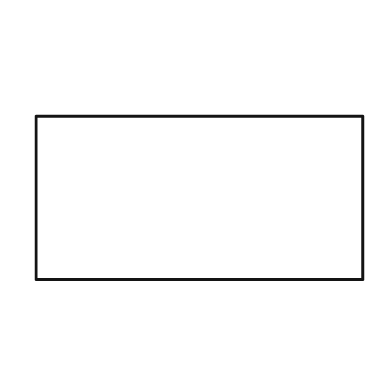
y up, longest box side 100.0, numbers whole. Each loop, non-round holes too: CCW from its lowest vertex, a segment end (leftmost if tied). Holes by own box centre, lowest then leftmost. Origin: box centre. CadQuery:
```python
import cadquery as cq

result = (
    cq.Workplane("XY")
    .moveTo(-50.0, -25.0)
    .lineTo(50.0, -25.0)
    .lineTo(50.0, 25.0)
    .lineTo(-50.0, 25.0)
    .close()
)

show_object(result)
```